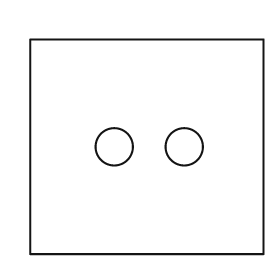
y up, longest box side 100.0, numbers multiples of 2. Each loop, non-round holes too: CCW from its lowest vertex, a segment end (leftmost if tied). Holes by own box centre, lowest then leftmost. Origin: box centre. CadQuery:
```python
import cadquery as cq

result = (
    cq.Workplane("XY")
    .moveTo(-50.0, -46.0)
    .lineTo(50.0, -46.0)
    .lineTo(50.0, 46.0)
    .lineTo(-50.0, 46.0)
    .close()
    .moveTo(-14.0, 0.0)
    .circle(8.0)
    .moveTo(16.0, 0.0)
    .circle(8.0)
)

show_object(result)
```